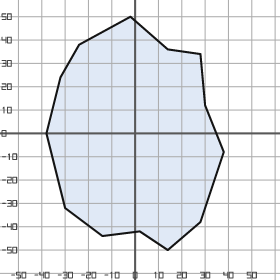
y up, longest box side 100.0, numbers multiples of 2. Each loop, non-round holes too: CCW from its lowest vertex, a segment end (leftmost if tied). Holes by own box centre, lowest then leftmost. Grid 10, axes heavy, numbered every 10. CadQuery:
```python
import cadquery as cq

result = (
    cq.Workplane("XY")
    .moveTo(14.0, -50.0)
    .lineTo(28.0, -38.0)
    .lineTo(38.0, -8.0)
    .lineTo(30.0, 12.0)
    .lineTo(28.0, 34.0)
    .lineTo(14.0, 36.0)
    .lineTo(-2.0, 50.0)
    .lineTo(-24.0, 38.0)
    .lineTo(-32.0, 24.0)
    .lineTo(-38.0, 0.0)
    .lineTo(-30.0, -32.0)
    .lineTo(-14.0, -44.0)
    .lineTo(2.0, -42.0)
    .close()
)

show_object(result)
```